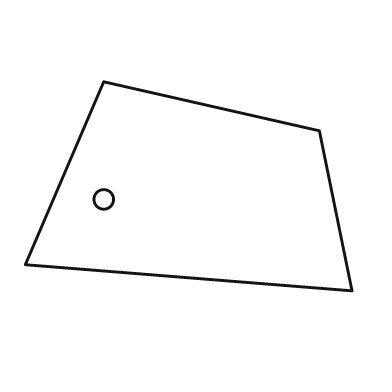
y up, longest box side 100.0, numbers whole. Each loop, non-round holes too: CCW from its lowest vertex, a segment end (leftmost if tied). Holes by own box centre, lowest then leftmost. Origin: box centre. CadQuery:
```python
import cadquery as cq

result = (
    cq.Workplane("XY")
    .moveTo(50.0, -32.0)
    .lineTo(40.0, 17.0)
    .lineTo(-26.0, 32.0)
    .lineTo(-50.0, -24.0)
    .close()
    .moveTo(-26.0, -4.0)
    .circle(3.0)
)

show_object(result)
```